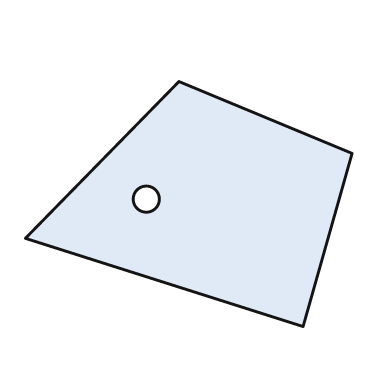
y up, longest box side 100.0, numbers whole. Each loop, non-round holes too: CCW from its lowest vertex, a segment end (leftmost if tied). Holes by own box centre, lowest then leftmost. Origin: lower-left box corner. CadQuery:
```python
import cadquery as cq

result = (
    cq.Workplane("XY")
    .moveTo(85.0, 0.0)
    .lineTo(100.0, 53.0)
    .lineTo(47.0, 75.0)
    .lineTo(0.0, 27.0)
    .close()
    .moveTo(37.0, 39.0)
    .circle(4.0)
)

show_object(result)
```